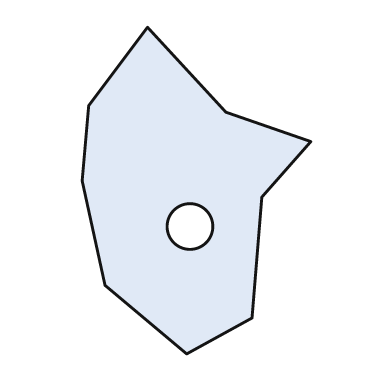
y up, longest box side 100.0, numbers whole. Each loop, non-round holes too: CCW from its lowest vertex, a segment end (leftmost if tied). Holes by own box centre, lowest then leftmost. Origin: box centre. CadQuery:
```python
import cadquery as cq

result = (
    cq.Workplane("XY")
    .moveTo(-3.0, -50.0)
    .lineTo(17.0, -39.0)
    .lineTo(20.0, -2.0)
    .lineTo(35.0, 15.0)
    .lineTo(9.0, 24.0)
    .lineTo(-15.0, 50.0)
    .lineTo(-33.0, 26.0)
    .lineTo(-35.0, 3.0)
    .lineTo(-28.0, -29.0)
    .close()
    .moveTo(-2.0, -11.0)
    .circle(7.0)
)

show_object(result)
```